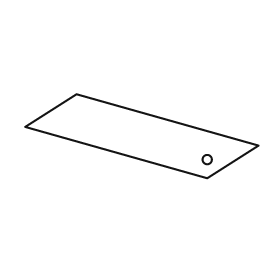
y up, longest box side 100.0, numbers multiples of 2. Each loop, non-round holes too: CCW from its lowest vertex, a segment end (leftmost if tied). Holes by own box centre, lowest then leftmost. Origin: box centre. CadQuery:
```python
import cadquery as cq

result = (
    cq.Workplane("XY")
    .moveTo(28.0, -18.0)
    .lineTo(50.0, -4.0)
    .lineTo(-28.0, 18.0)
    .lineTo(-50.0, 4.0)
    .close()
    .moveTo(28.0, -10.0)
    .circle(2.0)
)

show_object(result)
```